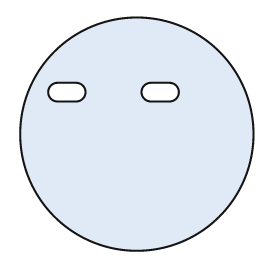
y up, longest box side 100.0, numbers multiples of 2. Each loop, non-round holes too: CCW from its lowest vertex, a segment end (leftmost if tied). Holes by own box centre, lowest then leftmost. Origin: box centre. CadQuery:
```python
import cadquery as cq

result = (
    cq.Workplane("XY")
    .moveTo(0.0, 0.0)
    .circle(50.0)
    .moveTo(-34.0, 14.0)
    .lineTo(-26.0, 14.0)
    .threePointArc((-22.0, 18.0), (-26.0, 22.0))
    .lineTo(-34.0, 22.0)
    .threePointArc((-38.0, 18.0), (-34.0, 14.0))
    .close()
    .moveTo(6.0, 14.0)
    .lineTo(14.0, 14.0)
    .threePointArc((18.0, 18.0), (14.0, 22.0))
    .lineTo(6.0, 22.0)
    .threePointArc((2.0, 18.0), (6.0, 14.0))
    .close()
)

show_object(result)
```